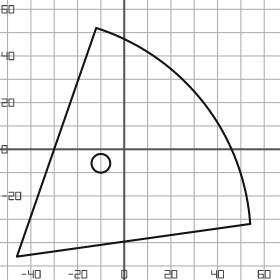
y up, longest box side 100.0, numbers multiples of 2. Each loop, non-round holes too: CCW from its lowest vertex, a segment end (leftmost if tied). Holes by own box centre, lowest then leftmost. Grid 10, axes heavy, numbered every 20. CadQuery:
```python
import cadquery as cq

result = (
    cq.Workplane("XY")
    .moveTo(-46.0, -46.0)
    .lineTo(54.0, -32.0)
    .threePointArc((34.0, 20.0), (-12.0, 52.0))
    .close()
    .moveTo(-10.0, -6.0)
    .circle(4.0)
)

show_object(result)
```